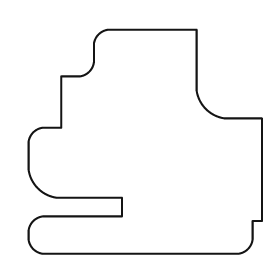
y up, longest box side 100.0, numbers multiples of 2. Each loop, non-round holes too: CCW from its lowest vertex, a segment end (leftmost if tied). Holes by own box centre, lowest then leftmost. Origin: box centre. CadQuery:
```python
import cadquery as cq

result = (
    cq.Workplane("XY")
    .moveTo(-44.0, -48.0)
    .lineTo(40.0, -48.0)
    .threePointArc((44.0, -46.0), (46.0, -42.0))
    .lineTo(46.0, -34.0)
    .lineTo(50.0, -34.0)
    .lineTo(50.0, 10.0)
    .lineTo(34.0, 10.0)
    .threePointArc((26.0, 14.0), (22.0, 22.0))
    .lineTo(22.0, 48.0)
    .lineTo(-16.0, 48.0)
    .threePointArc((-20.0, 46.0), (-22.0, 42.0))
    .lineTo(-22.0, 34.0)
    .threePointArc((-24.0, 30.0), (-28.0, 28.0))
    .lineTo(-36.0, 28.0)
    .lineTo(-36.0, 6.0)
    .lineTo(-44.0, 6.0)
    .threePointArc((-48.0, 4.0), (-50.0, 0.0))
    .lineTo(-50.0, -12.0)
    .threePointArc((-46.0, -20.0), (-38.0, -24.0))
    .lineTo(-10.0, -24.0)
    .lineTo(-10.0, -32.0)
    .lineTo(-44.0, -32.0)
    .threePointArc((-48.0, -34.0), (-50.0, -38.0))
    .lineTo(-50.0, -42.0)
    .threePointArc((-48.0, -46.0), (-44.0, -48.0))
    .close()
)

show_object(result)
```